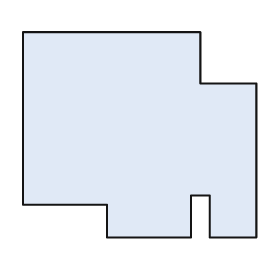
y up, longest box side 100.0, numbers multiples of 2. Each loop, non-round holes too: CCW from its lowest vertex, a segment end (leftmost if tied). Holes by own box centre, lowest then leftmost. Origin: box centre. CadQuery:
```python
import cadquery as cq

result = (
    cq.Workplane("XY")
    .moveTo(-14.0, -44.0)
    .lineTo(22.0, -44.0)
    .lineTo(22.0, -26.0)
    .lineTo(30.0, -26.0)
    .lineTo(30.0, -44.0)
    .lineTo(50.0, -44.0)
    .lineTo(50.0, 22.0)
    .lineTo(26.0, 22.0)
    .lineTo(26.0, 44.0)
    .lineTo(-50.0, 44.0)
    .lineTo(-50.0, -30.0)
    .lineTo(-14.0, -30.0)
    .close()
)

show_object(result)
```